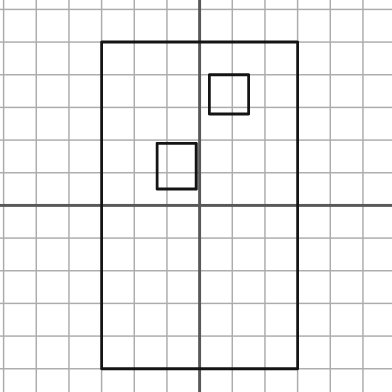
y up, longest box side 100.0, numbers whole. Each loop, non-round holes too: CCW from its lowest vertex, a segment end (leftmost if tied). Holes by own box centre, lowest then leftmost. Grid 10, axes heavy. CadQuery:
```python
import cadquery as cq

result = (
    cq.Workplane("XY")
    .moveTo(-30.0, -50.0)
    .lineTo(30.0, -50.0)
    .lineTo(30.0, 50.0)
    .lineTo(-30.0, 50.0)
    .close()
    .moveTo(-13.0, 5.0)
    .lineTo(-1.0, 5.0)
    .lineTo(-1.0, 19.0)
    .lineTo(-13.0, 19.0)
    .close()
    .moveTo(3.0, 28.0)
    .lineTo(15.0, 28.0)
    .lineTo(15.0, 40.0)
    .lineTo(3.0, 40.0)
    .close()
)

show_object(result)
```